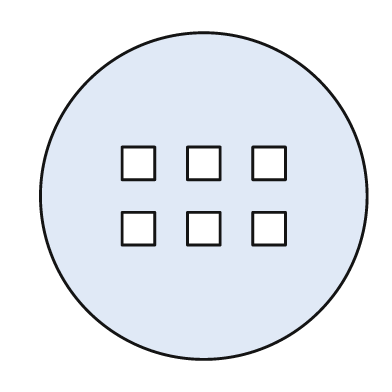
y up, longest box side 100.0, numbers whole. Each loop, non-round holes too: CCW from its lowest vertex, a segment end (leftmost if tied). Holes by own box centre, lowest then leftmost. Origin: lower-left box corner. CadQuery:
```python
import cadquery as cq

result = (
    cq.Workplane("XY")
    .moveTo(50.0, 50.0)
    .circle(50.0)
    .moveTo(25.0, 35.0)
    .lineTo(35.0, 35.0)
    .lineTo(35.0, 45.0)
    .lineTo(25.0, 45.0)
    .close()
    .moveTo(45.0, 35.0)
    .lineTo(55.0, 35.0)
    .lineTo(55.0, 45.0)
    .lineTo(45.0, 45.0)
    .close()
    .moveTo(65.0, 35.0)
    .lineTo(75.0, 35.0)
    .lineTo(75.0, 45.0)
    .lineTo(65.0, 45.0)
    .close()
    .moveTo(25.0, 55.0)
    .lineTo(35.0, 55.0)
    .lineTo(35.0, 65.0)
    .lineTo(25.0, 65.0)
    .close()
    .moveTo(45.0, 55.0)
    .lineTo(55.0, 55.0)
    .lineTo(55.0, 65.0)
    .lineTo(45.0, 65.0)
    .close()
    .moveTo(65.0, 55.0)
    .lineTo(75.0, 55.0)
    .lineTo(75.0, 65.0)
    .lineTo(65.0, 65.0)
    .close()
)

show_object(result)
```